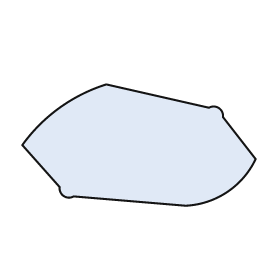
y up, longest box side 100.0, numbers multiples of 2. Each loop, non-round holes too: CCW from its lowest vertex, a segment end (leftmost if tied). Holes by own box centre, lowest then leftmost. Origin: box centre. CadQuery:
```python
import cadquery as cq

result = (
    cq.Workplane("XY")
    .moveTo(20.0, -26.0)
    .threePointArc((38.0, -20.0), (50.0, -6.0))
    .lineTo(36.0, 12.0)
    .threePointArc((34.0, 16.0), (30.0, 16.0))
    .lineTo(-14.0, 26.0)
    .threePointArc((-34.0, 16.0), (-50.0, 0.0))
    .lineTo(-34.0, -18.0)
    .threePointArc((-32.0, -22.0), (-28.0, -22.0))
    .close()
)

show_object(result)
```